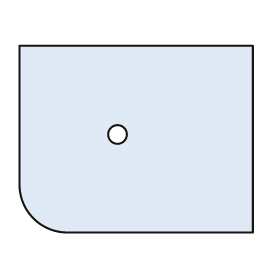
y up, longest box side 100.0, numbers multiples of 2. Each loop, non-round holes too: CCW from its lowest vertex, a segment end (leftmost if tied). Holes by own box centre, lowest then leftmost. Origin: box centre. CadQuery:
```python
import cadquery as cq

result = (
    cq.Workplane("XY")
    .moveTo(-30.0, -40.0)
    .lineTo(50.0, -40.0)
    .lineTo(50.0, 40.0)
    .lineTo(-50.0, 40.0)
    .lineTo(-50.0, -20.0)
    .threePointArc((-44.0, -34.0), (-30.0, -40.0))
    .close()
    .moveTo(-8.0, 2.0)
    .circle(4.0)
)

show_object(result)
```